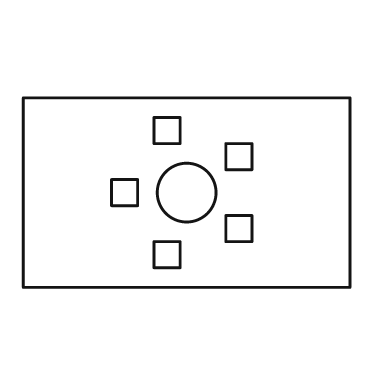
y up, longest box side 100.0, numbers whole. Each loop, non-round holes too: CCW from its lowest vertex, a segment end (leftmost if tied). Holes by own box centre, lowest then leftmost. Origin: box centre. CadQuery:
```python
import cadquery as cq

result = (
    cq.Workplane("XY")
    .moveTo(-50.0, -29.0)
    .lineTo(50.0, -29.0)
    .lineTo(50.0, 29.0)
    .lineTo(-50.0, 29.0)
    .close()
    .moveTo(-10.0, -23.0)
    .lineTo(-2.0, -23.0)
    .lineTo(-2.0, -15.0)
    .lineTo(-10.0, -15.0)
    .close()
    .moveTo(12.0, -15.0)
    .lineTo(20.0, -15.0)
    .lineTo(20.0, -7.0)
    .lineTo(12.0, -7.0)
    .close()
    .moveTo(-23.0, -4.0)
    .lineTo(-15.0, -4.0)
    .lineTo(-15.0, 4.0)
    .lineTo(-23.0, 4.0)
    .close()
    .moveTo(0.0, 0.0)
    .circle(9.0)
    .moveTo(12.0, 7.0)
    .lineTo(20.0, 7.0)
    .lineTo(20.0, 15.0)
    .lineTo(12.0, 15.0)
    .close()
    .moveTo(-10.0, 15.0)
    .lineTo(-2.0, 15.0)
    .lineTo(-2.0, 23.0)
    .lineTo(-10.0, 23.0)
    .close()
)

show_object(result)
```